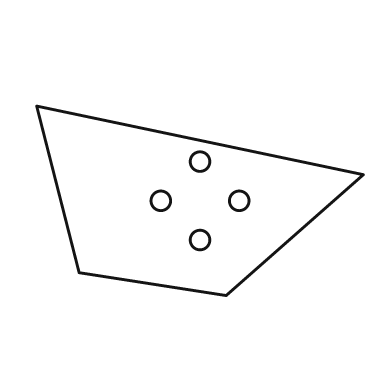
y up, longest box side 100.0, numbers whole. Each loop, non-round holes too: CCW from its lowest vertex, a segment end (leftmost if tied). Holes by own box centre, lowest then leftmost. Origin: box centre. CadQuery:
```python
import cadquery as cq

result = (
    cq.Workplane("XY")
    .moveTo(8.0, -29.0)
    .lineTo(50.0, 8.0)
    .lineTo(-50.0, 29.0)
    .lineTo(-37.0, -22.0)
    .close()
    .moveTo(0.0, -12.0)
    .circle(3.0)
    .moveTo(-12.0, 0.0)
    .circle(3.0)
    .moveTo(12.0, 0.0)
    .circle(3.0)
    .moveTo(0.0, 12.0)
    .circle(3.0)
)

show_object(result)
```